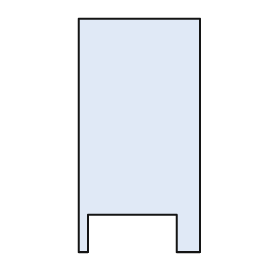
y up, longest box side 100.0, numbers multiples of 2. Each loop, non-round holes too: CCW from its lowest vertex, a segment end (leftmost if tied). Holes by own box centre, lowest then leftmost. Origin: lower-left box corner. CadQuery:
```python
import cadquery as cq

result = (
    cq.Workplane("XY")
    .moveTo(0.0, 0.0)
    .lineTo(4.0, 0.0)
    .lineTo(4.0, 16.0)
    .lineTo(42.0, 16.0)
    .lineTo(42.0, 0.0)
    .lineTo(52.0, 0.0)
    .lineTo(52.0, 100.0)
    .lineTo(0.0, 100.0)
    .close()
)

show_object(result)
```